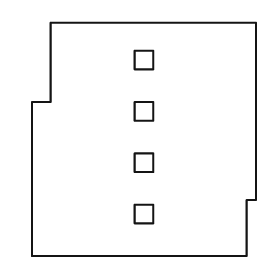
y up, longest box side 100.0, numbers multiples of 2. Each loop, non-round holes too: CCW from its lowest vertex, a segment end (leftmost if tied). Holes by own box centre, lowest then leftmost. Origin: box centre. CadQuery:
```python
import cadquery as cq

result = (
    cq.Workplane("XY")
    .moveTo(-48.0, -50.0)
    .lineTo(44.0, -50.0)
    .lineTo(44.0, -26.0)
    .lineTo(48.0, -26.0)
    .lineTo(48.0, 50.0)
    .lineTo(-40.0, 50.0)
    .lineTo(-40.0, 16.0)
    .lineTo(-48.0, 16.0)
    .close()
    .moveTo(-4.0, -36.0)
    .lineTo(4.0, -36.0)
    .lineTo(4.0, -28.0)
    .lineTo(-4.0, -28.0)
    .close()
    .moveTo(-4.0, -14.0)
    .lineTo(4.0, -14.0)
    .lineTo(4.0, -6.0)
    .lineTo(-4.0, -6.0)
    .close()
    .moveTo(-4.0, 8.0)
    .lineTo(4.0, 8.0)
    .lineTo(4.0, 16.0)
    .lineTo(-4.0, 16.0)
    .close()
    .moveTo(-4.0, 30.0)
    .lineTo(4.0, 30.0)
    .lineTo(4.0, 38.0)
    .lineTo(-4.0, 38.0)
    .close()
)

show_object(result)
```